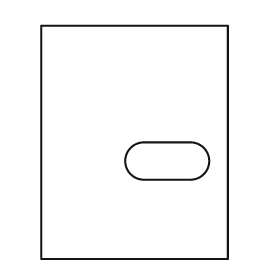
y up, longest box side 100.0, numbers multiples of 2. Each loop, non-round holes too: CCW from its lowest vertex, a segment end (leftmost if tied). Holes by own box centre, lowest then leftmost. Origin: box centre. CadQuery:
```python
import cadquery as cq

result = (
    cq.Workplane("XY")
    .moveTo(-40.0, -50.0)
    .lineTo(40.0, -50.0)
    .lineTo(40.0, 50.0)
    .lineTo(-40.0, 50.0)
    .close()
    .moveTo(4.0, -16.0)
    .lineTo(24.0, -16.0)
    .threePointArc((32.0, -8.0), (24.0, 0.0))
    .lineTo(4.0, 0.0)
    .threePointArc((-4.0, -8.0), (4.0, -16.0))
    .close()
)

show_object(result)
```